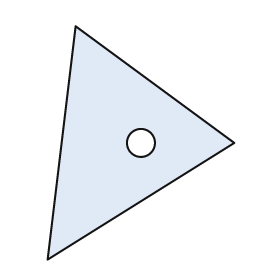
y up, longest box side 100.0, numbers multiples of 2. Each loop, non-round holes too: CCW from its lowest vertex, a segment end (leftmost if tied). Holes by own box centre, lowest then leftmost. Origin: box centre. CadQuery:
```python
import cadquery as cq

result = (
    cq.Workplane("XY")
    .moveTo(-40.0, -50.0)
    .lineTo(40.0, 0.0)
    .lineTo(-28.0, 50.0)
    .close()
    .moveTo(0.0, 0.0)
    .circle(6.0)
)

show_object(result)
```